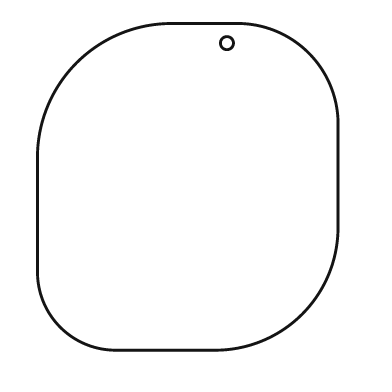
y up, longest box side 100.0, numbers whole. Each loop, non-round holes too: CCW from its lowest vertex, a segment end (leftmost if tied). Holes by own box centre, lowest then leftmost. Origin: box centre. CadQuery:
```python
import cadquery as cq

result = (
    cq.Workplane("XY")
    .moveTo(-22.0, -50.0)
    .lineTo(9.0, -50.0)
    .threePointArc((35.0, -39.0), (46.0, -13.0))
    .lineTo(46.0, 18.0)
    .threePointArc((37.0, 41.0), (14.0, 50.0))
    .lineTo(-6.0, 50.0)
    .threePointArc((-34.0, 38.0), (-46.0, 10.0))
    .lineTo(-46.0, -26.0)
    .threePointArc((-39.0, -43.0), (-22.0, -50.0))
    .close()
    .moveTo(12.0, 44.0)
    .circle(2.0)
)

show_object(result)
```